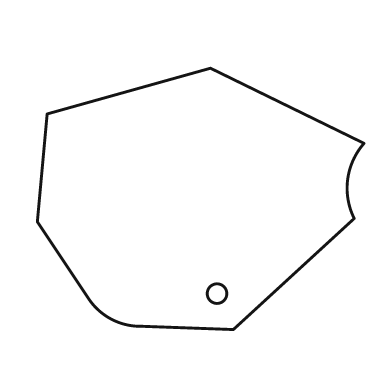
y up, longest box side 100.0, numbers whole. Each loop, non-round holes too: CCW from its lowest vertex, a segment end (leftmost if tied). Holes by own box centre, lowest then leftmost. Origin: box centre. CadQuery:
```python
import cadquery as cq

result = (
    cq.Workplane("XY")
    .moveTo(10.0, -40.0)
    .lineTo(47.0, -6.0)
    .threePointArc((45.0, 6.0), (50.0, 17.0))
    .lineTo(3.0, 40.0)
    .lineTo(-47.0, 26.0)
    .lineTo(-50.0, -7.0)
    .lineTo(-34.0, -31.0)
    .threePointArc((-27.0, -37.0), (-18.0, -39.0))
    .close()
    .moveTo(5.0, -29.0)
    .circle(3.0)
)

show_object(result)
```